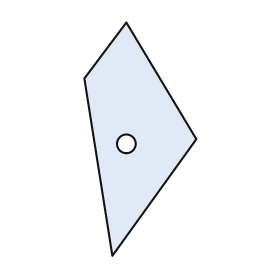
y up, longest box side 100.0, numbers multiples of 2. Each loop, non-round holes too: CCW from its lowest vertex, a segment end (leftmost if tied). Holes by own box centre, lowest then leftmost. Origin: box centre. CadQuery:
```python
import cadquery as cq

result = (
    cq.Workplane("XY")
    .moveTo(-12.0, -50.0)
    .lineTo(24.0, 0.0)
    .lineTo(-6.0, 50.0)
    .lineTo(-24.0, 26.0)
    .close()
    .moveTo(-6.0, -2.0)
    .circle(4.0)
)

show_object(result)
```